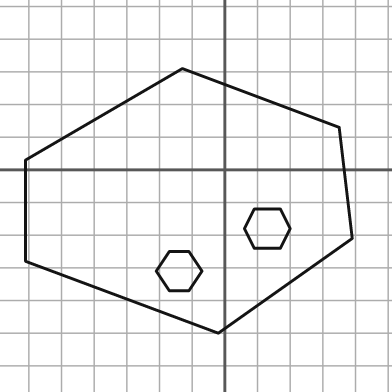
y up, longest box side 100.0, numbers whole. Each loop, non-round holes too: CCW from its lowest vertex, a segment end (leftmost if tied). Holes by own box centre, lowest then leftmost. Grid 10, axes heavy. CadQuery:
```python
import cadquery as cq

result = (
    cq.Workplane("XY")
    .moveTo(-2.0, -50.0)
    .lineTo(39.0, -21.0)
    .lineTo(35.0, 13.0)
    .lineTo(-13.0, 31.0)
    .lineTo(-61.0, 3.0)
    .lineTo(-61.0, -28.0)
    .close()
    .moveTo(-17.0, -37.0)
    .lineTo(-11.0, -37.0)
    .lineTo(-7.0, -31.0)
    .lineTo(-11.0, -25.0)
    .lineTo(-17.0, -25.0)
    .lineTo(-21.0, -31.0)
    .close()
    .moveTo(9.0, -24.0)
    .lineTo(17.0, -24.0)
    .lineTo(20.0, -18.0)
    .lineTo(17.0, -12.0)
    .lineTo(9.0, -12.0)
    .lineTo(6.0, -18.0)
    .close()
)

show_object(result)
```